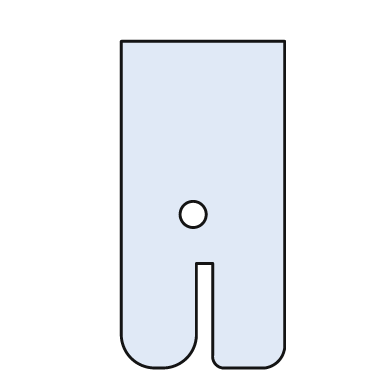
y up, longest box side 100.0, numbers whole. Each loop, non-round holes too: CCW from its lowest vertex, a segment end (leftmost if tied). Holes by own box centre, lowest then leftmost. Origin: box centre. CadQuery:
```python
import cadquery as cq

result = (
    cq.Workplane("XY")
    .moveTo(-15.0, -50.0)
    .lineTo(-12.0, -50.0)
    .threePointArc((-5.0, -47.0), (-2.0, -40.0))
    .lineTo(-2.0, -18.0)
    .lineTo(3.0, -18.0)
    .lineTo(3.0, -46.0)
    .threePointArc((4.0, -49.0), (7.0, -50.0))
    .lineTo(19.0, -50.0)
    .threePointArc((23.0, -48.0), (25.0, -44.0))
    .lineTo(25.0, 50.0)
    .lineTo(-25.0, 50.0)
    .lineTo(-25.0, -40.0)
    .threePointArc((-22.0, -47.0), (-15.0, -50.0))
    .close()
    .moveTo(-3.0, -3.0)
    .circle(4.0)
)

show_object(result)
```